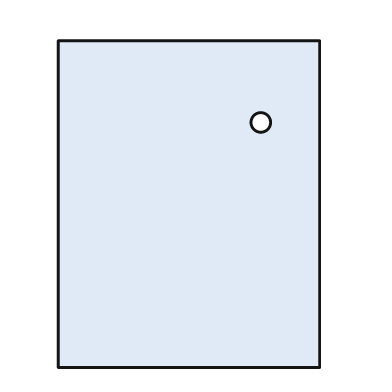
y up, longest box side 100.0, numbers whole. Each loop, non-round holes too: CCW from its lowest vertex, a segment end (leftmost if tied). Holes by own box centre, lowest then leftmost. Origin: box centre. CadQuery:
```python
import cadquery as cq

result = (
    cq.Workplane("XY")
    .moveTo(-40.0, -50.0)
    .lineTo(40.0, -50.0)
    .lineTo(40.0, 50.0)
    .lineTo(-40.0, 50.0)
    .close()
    .moveTo(22.0, 25.0)
    .circle(3.0)
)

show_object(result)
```